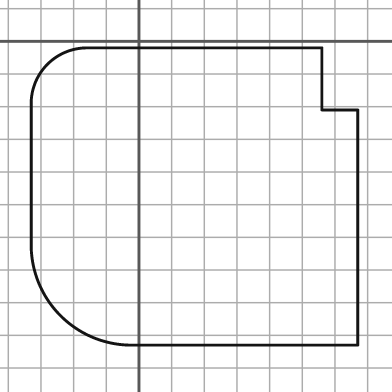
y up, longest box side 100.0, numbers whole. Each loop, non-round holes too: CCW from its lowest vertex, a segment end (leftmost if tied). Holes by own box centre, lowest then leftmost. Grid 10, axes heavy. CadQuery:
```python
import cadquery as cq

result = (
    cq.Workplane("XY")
    .moveTo(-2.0, -93.0)
    .lineTo(67.0, -93.0)
    .lineTo(67.0, -21.0)
    .lineTo(56.0, -21.0)
    .lineTo(56.0, -2.0)
    .lineTo(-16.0, -2.0)
    .threePointArc((-28.0, -7.0), (-33.0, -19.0))
    .lineTo(-33.0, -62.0)
    .threePointArc((-24.0, -84.0), (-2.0, -93.0))
    .close()
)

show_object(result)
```